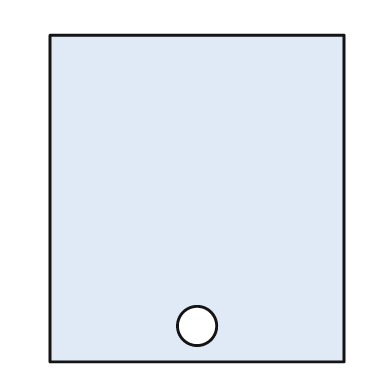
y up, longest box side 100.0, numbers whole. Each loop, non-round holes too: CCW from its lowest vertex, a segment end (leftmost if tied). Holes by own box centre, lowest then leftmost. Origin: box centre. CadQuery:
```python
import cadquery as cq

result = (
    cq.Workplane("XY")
    .moveTo(-45.0, -50.0)
    .lineTo(45.0, -50.0)
    .lineTo(45.0, 50.0)
    .lineTo(-45.0, 50.0)
    .close()
    .moveTo(0.0, -39.0)
    .circle(6.0)
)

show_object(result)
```